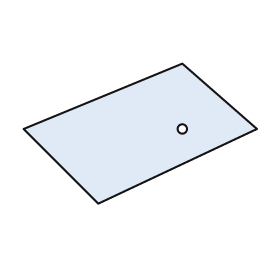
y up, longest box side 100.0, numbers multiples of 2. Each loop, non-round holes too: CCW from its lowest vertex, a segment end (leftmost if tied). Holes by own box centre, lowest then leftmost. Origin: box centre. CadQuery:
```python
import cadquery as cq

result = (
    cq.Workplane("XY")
    .moveTo(-18.0, -30.0)
    .lineTo(50.0, 2.0)
    .lineTo(18.0, 30.0)
    .lineTo(-50.0, 2.0)
    .close()
    .moveTo(18.0, 2.0)
    .circle(2.0)
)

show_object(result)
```